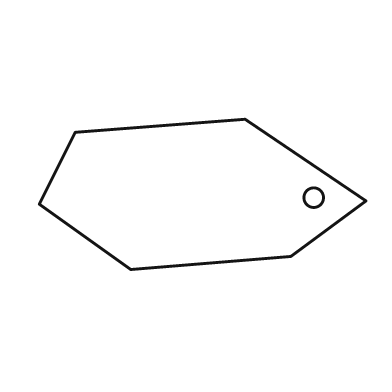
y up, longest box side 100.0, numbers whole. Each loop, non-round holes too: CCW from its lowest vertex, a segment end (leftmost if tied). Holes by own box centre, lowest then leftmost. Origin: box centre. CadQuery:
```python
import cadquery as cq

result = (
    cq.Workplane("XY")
    .moveTo(-22.0, -23.0)
    .lineTo(27.0, -19.0)
    .lineTo(50.0, -2.0)
    .lineTo(13.0, 23.0)
    .lineTo(-39.0, 19.0)
    .lineTo(-50.0, -3.0)
    .close()
    .moveTo(34.0, -1.0)
    .circle(3.0)
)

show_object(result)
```